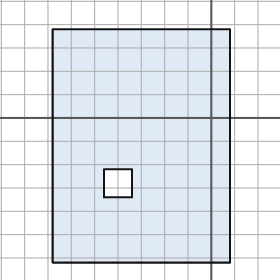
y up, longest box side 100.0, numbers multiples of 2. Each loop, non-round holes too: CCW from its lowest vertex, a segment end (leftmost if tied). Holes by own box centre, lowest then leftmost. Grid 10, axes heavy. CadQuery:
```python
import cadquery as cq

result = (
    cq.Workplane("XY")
    .moveTo(-68.0, -62.0)
    .lineTo(8.0, -62.0)
    .lineTo(8.0, 38.0)
    .lineTo(-68.0, 38.0)
    .close()
    .moveTo(-46.0, -34.0)
    .lineTo(-34.0, -34.0)
    .lineTo(-34.0, -22.0)
    .lineTo(-46.0, -22.0)
    .close()
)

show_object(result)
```